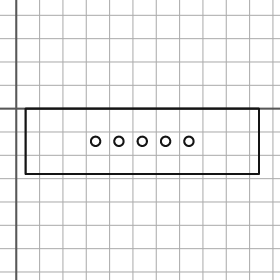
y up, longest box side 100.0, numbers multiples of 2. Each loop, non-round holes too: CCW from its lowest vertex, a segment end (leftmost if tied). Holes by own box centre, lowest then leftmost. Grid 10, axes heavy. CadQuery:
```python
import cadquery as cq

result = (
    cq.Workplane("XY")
    .moveTo(4.0, -28.0)
    .lineTo(104.0, -28.0)
    .lineTo(104.0, 0.0)
    .lineTo(4.0, 0.0)
    .close()
    .moveTo(34.0, -14.0)
    .circle(2.0)
    .moveTo(44.0, -14.0)
    .circle(2.0)
    .moveTo(54.0, -14.0)
    .circle(2.0)
    .moveTo(64.0, -14.0)
    .circle(2.0)
    .moveTo(74.0, -14.0)
    .circle(2.0)
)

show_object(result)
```